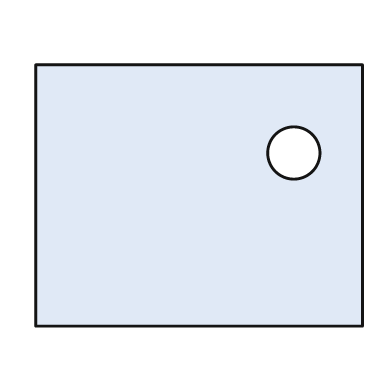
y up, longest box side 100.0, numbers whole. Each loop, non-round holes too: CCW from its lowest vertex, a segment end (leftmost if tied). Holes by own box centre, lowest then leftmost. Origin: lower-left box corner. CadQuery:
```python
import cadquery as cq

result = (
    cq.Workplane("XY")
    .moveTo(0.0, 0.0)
    .lineTo(100.0, 0.0)
    .lineTo(100.0, 80.0)
    .lineTo(0.0, 80.0)
    .close()
    .moveTo(79.0, 53.0)
    .circle(8.0)
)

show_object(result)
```